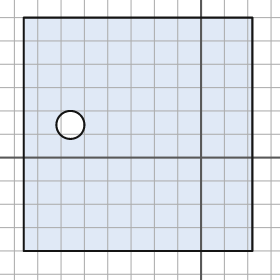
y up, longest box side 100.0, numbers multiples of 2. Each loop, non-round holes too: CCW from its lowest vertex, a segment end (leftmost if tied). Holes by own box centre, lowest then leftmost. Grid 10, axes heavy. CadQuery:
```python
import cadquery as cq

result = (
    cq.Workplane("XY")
    .moveTo(-76.0, -40.0)
    .lineTo(22.0, -40.0)
    .lineTo(22.0, 60.0)
    .lineTo(-76.0, 60.0)
    .close()
    .moveTo(-56.0, 14.0)
    .circle(6.0)
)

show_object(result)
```